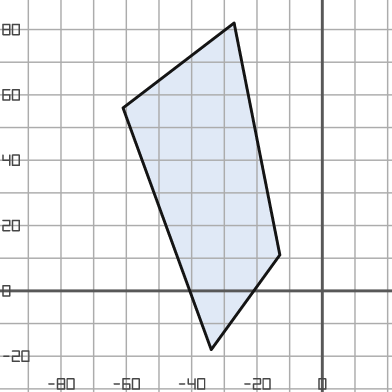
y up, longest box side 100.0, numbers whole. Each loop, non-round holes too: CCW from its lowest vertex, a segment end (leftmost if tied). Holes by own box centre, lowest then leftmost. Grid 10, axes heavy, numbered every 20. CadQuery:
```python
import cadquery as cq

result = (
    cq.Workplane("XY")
    .moveTo(-34.0, -18.0)
    .lineTo(-13.0, 11.0)
    .lineTo(-27.0, 82.0)
    .lineTo(-61.0, 56.0)
    .close()
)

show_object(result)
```